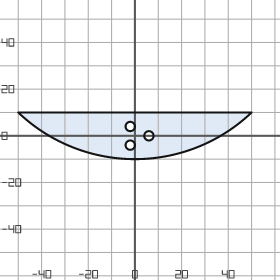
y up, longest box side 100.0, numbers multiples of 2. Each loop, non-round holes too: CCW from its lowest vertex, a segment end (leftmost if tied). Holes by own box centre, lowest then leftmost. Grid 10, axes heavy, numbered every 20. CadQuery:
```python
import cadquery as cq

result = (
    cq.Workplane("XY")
    .moveTo(-50.0, 10.0)
    .threePointArc((0.0, -10.0), (50.0, 10.0))
    .close()
    .moveTo(-2.0, -4.0)
    .circle(2.0)
    .moveTo(6.0, 0.0)
    .circle(2.0)
    .moveTo(-2.0, 4.0)
    .circle(2.0)
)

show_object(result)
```